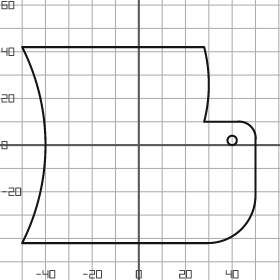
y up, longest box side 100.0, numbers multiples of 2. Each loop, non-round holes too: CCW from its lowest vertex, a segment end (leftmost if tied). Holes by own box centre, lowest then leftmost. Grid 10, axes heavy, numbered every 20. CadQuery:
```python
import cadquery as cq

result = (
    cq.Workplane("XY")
    .moveTo(-50.0, -42.0)
    .lineTo(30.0, -42.0)
    .threePointArc((44.0, -36.0), (50.0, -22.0))
    .lineTo(50.0, 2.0)
    .threePointArc((48.0, 8.0), (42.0, 10.0))
    .lineTo(28.0, 10.0)
    .threePointArc((30.0, 26.0), (28.0, 42.0))
    .lineTo(-50.0, 42.0)
    .threePointArc((-40.0, 0.0), (-50.0, -42.0))
    .close()
    .moveTo(40.0, 2.0)
    .circle(2.0)
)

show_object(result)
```